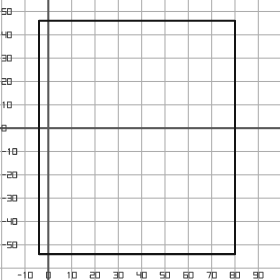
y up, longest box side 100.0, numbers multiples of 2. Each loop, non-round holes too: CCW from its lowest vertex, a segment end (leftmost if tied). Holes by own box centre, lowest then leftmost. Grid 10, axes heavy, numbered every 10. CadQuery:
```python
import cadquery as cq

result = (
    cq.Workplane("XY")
    .moveTo(-4.0, -54.0)
    .lineTo(80.0, -54.0)
    .lineTo(80.0, 46.0)
    .lineTo(-4.0, 46.0)
    .close()
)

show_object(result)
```